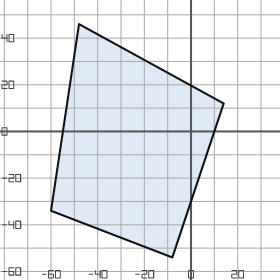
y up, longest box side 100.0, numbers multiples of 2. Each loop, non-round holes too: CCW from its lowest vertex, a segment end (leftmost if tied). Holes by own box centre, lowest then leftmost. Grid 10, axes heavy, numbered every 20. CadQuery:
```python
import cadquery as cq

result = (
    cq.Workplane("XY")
    .moveTo(-8.0, -54.0)
    .lineTo(14.0, 12.0)
    .lineTo(-48.0, 46.0)
    .lineTo(-60.0, -34.0)
    .close()
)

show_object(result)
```